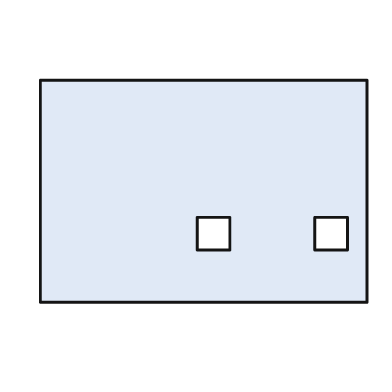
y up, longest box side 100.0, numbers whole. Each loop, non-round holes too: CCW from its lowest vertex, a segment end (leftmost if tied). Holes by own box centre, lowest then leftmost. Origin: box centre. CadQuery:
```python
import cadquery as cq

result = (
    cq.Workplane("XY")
    .moveTo(-50.0, -34.0)
    .lineTo(50.0, -34.0)
    .lineTo(50.0, 34.0)
    .lineTo(-50.0, 34.0)
    .close()
    .moveTo(-2.0, -18.0)
    .lineTo(8.0, -18.0)
    .lineTo(8.0, -8.0)
    .lineTo(-2.0, -8.0)
    .close()
    .moveTo(34.0, -18.0)
    .lineTo(44.0, -18.0)
    .lineTo(44.0, -8.0)
    .lineTo(34.0, -8.0)
    .close()
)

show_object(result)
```